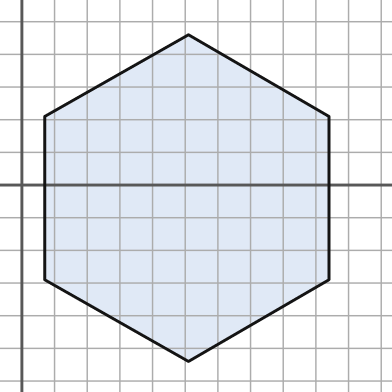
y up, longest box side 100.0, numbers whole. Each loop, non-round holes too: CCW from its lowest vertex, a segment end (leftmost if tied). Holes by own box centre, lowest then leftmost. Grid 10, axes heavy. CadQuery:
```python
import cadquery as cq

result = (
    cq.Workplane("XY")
    .moveTo(51.0, -54.0)
    .lineTo(94.0, -29.0)
    .lineTo(94.0, 21.0)
    .lineTo(51.0, 46.0)
    .lineTo(7.0, 21.0)
    .lineTo(7.0, -29.0)
    .close()
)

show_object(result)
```